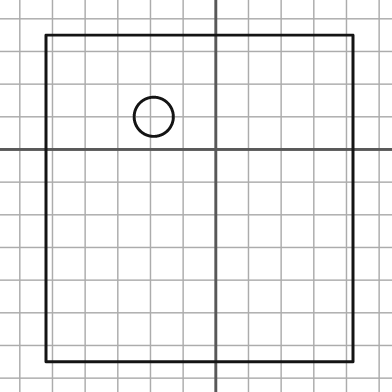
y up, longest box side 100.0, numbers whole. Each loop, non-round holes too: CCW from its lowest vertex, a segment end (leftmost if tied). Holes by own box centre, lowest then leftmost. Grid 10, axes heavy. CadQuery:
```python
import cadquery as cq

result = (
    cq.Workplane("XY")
    .moveTo(-52.0, -65.0)
    .lineTo(42.0, -65.0)
    .lineTo(42.0, 35.0)
    .lineTo(-52.0, 35.0)
    .close()
    .moveTo(-19.0, 10.0)
    .circle(6.0)
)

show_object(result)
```